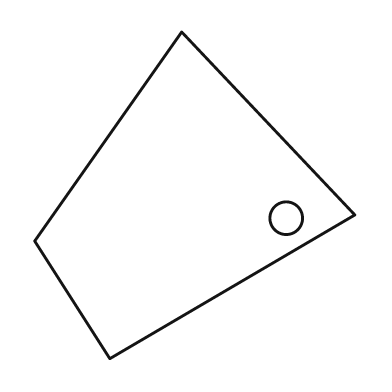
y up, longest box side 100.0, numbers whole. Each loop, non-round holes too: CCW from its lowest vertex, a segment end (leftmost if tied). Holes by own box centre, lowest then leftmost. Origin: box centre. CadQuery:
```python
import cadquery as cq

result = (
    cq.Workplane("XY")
    .moveTo(-26.0, -50.0)
    .lineTo(49.0, -6.0)
    .lineTo(-4.0, 50.0)
    .lineTo(-49.0, -14.0)
    .close()
    .moveTo(28.0, -7.0)
    .circle(5.0)
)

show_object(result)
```